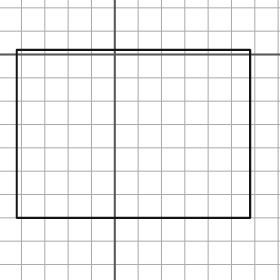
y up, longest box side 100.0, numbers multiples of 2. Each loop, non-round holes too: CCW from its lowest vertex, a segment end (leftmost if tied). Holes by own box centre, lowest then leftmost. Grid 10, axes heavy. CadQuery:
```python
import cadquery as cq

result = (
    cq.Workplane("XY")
    .moveTo(-42.0, -70.0)
    .lineTo(58.0, -70.0)
    .lineTo(58.0, 2.0)
    .lineTo(-42.0, 2.0)
    .close()
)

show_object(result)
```